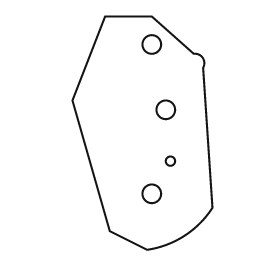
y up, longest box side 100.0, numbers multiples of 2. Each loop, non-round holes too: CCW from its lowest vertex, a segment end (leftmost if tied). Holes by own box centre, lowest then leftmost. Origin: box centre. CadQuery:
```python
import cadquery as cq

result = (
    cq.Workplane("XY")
    .moveTo(2.0, -50.0)
    .threePointArc((18.0, -44.0), (30.0, -32.0))
    .lineTo(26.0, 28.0)
    .threePointArc((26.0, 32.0), (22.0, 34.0))
    .lineTo(4.0, 50.0)
    .lineTo(-16.0, 50.0)
    .lineTo(-30.0, 14.0)
    .lineTo(-14.0, -42.0)
    .close()
    .moveTo(4.0, -26.0)
    .circle(4.0)
    .moveTo(12.0, -12.0)
    .circle(2.0)
    .moveTo(10.0, 10.0)
    .circle(4.0)
    .moveTo(4.0, 38.0)
    .circle(4.0)
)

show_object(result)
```